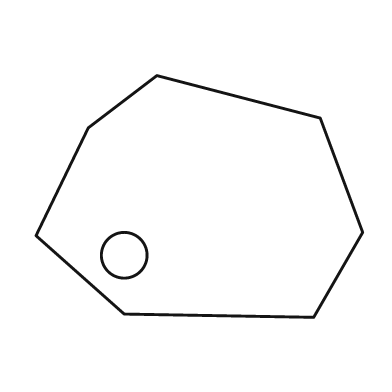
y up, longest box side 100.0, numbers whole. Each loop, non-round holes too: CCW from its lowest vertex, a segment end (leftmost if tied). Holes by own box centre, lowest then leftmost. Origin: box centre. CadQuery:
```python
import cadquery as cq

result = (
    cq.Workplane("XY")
    .moveTo(35.0, -37.0)
    .lineTo(50.0, -11.0)
    .lineTo(37.0, 24.0)
    .lineTo(-13.0, 37.0)
    .lineTo(-34.0, 21.0)
    .lineTo(-50.0, -12.0)
    .lineTo(-23.0, -36.0)
    .close()
    .moveTo(-23.0, -18.0)
    .circle(7.0)
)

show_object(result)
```